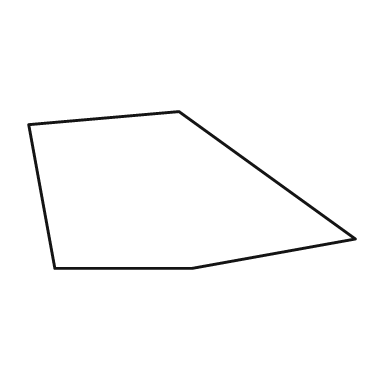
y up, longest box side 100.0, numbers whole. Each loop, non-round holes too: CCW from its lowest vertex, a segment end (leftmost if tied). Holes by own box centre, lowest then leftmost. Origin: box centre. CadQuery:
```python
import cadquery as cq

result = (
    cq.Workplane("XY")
    .moveTo(-42.0, -24.0)
    .lineTo(0.0, -24.0)
    .lineTo(50.0, -15.0)
    .lineTo(-4.0, 24.0)
    .lineTo(-50.0, 20.0)
    .close()
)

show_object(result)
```